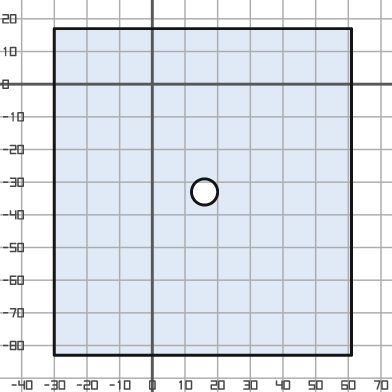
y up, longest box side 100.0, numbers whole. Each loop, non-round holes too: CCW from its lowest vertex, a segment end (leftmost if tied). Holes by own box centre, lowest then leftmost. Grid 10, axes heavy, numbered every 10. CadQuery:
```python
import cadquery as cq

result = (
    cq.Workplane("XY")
    .moveTo(-30.0, -83.0)
    .lineTo(61.0, -83.0)
    .lineTo(61.0, 17.0)
    .lineTo(-30.0, 17.0)
    .close()
    .moveTo(16.0, -33.0)
    .circle(4.0)
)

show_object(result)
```